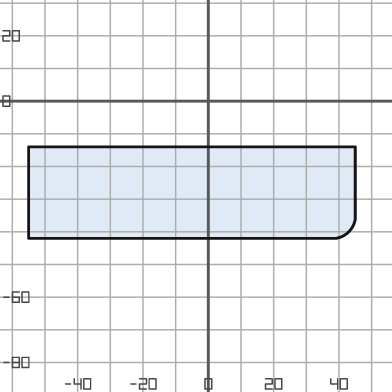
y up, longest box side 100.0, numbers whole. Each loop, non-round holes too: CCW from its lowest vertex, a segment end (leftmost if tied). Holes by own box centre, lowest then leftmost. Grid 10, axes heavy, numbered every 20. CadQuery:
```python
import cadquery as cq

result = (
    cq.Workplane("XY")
    .moveTo(-55.0, -42.0)
    .lineTo(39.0, -42.0)
    .threePointArc((43.0, -40.0), (45.0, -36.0))
    .lineTo(45.0, -14.0)
    .lineTo(-55.0, -14.0)
    .close()
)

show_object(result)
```